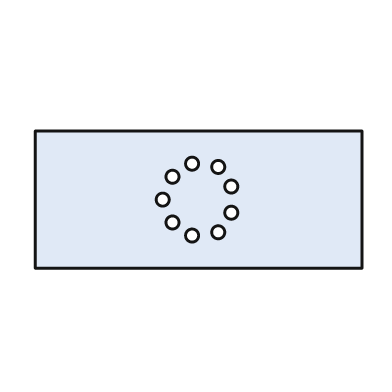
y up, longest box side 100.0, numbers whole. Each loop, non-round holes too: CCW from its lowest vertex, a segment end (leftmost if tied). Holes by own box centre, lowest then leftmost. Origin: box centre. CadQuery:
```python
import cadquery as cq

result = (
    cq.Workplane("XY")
    .moveTo(-50.0, -21.0)
    .lineTo(50.0, -21.0)
    .lineTo(50.0, 21.0)
    .lineTo(-50.0, 21.0)
    .close()
    .moveTo(-2.0, -11.0)
    .circle(2.0)
    .moveTo(6.0, -10.0)
    .circle(2.0)
    .moveTo(-8.0, -7.0)
    .circle(2.0)
    .moveTo(10.0, -4.0)
    .circle(2.0)
    .moveTo(-11.0, 0.0)
    .circle(2.0)
    .moveTo(10.0, 4.0)
    .circle(2.0)
    .moveTo(-8.0, 7.0)
    .circle(2.0)
    .moveTo(6.0, 10.0)
    .circle(2.0)
    .moveTo(-2.0, 11.0)
    .circle(2.0)
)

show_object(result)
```